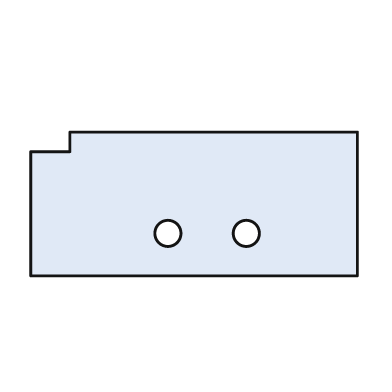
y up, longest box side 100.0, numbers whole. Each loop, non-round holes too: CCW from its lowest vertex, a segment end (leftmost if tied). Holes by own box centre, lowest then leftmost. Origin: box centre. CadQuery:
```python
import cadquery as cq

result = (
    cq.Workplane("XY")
    .moveTo(-50.0, -22.0)
    .lineTo(50.0, -22.0)
    .lineTo(50.0, 22.0)
    .lineTo(-38.0, 22.0)
    .lineTo(-38.0, 16.0)
    .lineTo(-50.0, 16.0)
    .close()
    .moveTo(-8.0, -9.0)
    .circle(4.0)
    .moveTo(16.0, -9.0)
    .circle(4.0)
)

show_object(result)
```